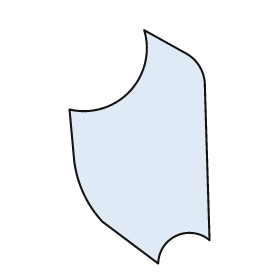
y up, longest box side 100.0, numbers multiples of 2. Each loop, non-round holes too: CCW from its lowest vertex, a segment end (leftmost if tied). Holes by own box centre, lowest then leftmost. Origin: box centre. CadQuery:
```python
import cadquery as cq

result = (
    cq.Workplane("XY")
    .moveTo(8.0, -50.0)
    .threePointArc((16.0, -38.0), (30.0, -40.0))
    .lineTo(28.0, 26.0)
    .threePointArc((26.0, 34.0), (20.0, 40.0))
    .lineTo(2.0, 50.0)
    .threePointArc((-4.0, 24.0), (-30.0, 16.0))
    .lineTo(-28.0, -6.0)
    .threePointArc((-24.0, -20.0), (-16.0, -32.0))
    .close()
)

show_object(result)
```